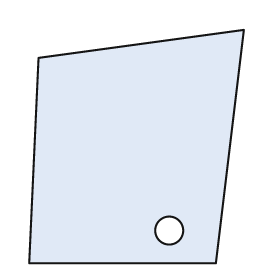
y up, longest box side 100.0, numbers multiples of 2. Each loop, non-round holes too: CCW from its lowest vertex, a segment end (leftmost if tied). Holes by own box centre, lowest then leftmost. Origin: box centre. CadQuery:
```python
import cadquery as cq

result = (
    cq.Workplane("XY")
    .moveTo(-46.0, -50.0)
    .lineTo(34.0, -50.0)
    .lineTo(46.0, 50.0)
    .lineTo(-42.0, 38.0)
    .close()
    .moveTo(14.0, -36.0)
    .circle(6.0)
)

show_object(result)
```